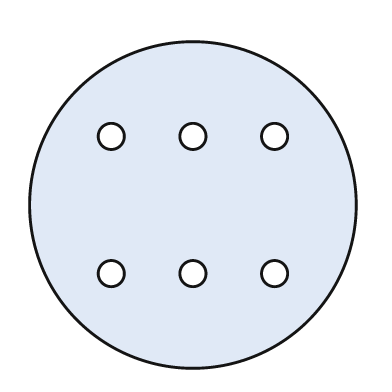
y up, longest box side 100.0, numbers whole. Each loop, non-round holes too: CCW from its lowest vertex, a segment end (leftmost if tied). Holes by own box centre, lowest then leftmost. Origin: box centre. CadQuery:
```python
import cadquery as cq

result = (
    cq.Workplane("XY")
    .moveTo(0.0, 0.0)
    .circle(50.0)
    .moveTo(-25.0, -21.0)
    .circle(4.0)
    .moveTo(0.0, -21.0)
    .circle(4.0)
    .moveTo(25.0, -21.0)
    .circle(4.0)
    .moveTo(-25.0, 21.0)
    .circle(4.0)
    .moveTo(0.0, 21.0)
    .circle(4.0)
    .moveTo(25.0, 21.0)
    .circle(4.0)
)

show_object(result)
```